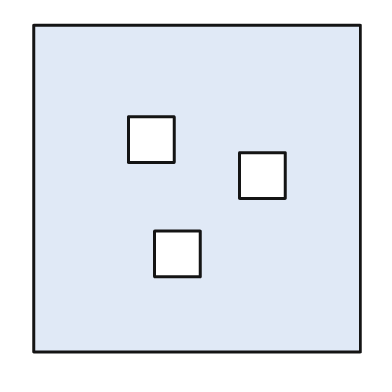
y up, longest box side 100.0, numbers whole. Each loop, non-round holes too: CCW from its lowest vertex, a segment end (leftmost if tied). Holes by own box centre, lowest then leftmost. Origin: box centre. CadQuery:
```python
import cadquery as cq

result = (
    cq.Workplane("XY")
    .moveTo(-50.0, -50.0)
    .lineTo(50.0, -50.0)
    .lineTo(50.0, 50.0)
    .lineTo(-50.0, 50.0)
    .close()
    .moveTo(-13.0, -27.0)
    .lineTo(1.0, -27.0)
    .lineTo(1.0, -13.0)
    .lineTo(-13.0, -13.0)
    .close()
    .moveTo(13.0, -3.0)
    .lineTo(27.0, -3.0)
    .lineTo(27.0, 11.0)
    .lineTo(13.0, 11.0)
    .close()
    .moveTo(-21.0, 8.0)
    .lineTo(-7.0, 8.0)
    .lineTo(-7.0, 22.0)
    .lineTo(-21.0, 22.0)
    .close()
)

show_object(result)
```